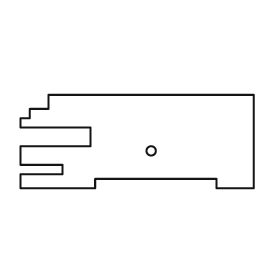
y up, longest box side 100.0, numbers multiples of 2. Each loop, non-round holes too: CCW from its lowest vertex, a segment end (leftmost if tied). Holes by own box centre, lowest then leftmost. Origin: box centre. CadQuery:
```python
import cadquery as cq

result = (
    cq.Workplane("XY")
    .moveTo(-50.0, -20.0)
    .lineTo(-18.0, -20.0)
    .lineTo(-18.0, -16.0)
    .lineTo(34.0, -16.0)
    .lineTo(34.0, -20.0)
    .lineTo(50.0, -20.0)
    .lineTo(50.0, 20.0)
    .lineTo(-38.0, 20.0)
    .lineTo(-38.0, 14.0)
    .lineTo(-46.0, 14.0)
    .lineTo(-46.0, 10.0)
    .lineTo(-50.0, 10.0)
    .lineTo(-50.0, 6.0)
    .lineTo(-20.0, 6.0)
    .lineTo(-20.0, -2.0)
    .lineTo(-50.0, -2.0)
    .lineTo(-50.0, -10.0)
    .lineTo(-32.0, -10.0)
    .lineTo(-32.0, -14.0)
    .lineTo(-50.0, -14.0)
    .close()
    .moveTo(6.0, -4.0)
    .circle(2.0)
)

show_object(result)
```